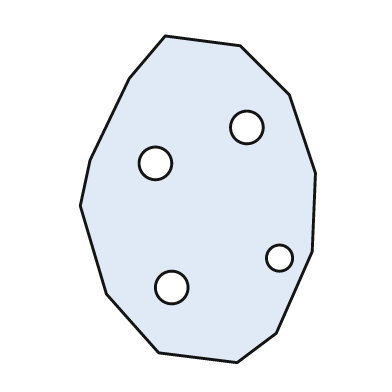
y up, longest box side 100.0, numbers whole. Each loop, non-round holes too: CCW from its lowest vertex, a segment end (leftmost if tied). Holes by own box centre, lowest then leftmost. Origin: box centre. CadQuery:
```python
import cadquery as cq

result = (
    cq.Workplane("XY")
    .moveTo(12.0, -50.0)
    .lineTo(24.0, -41.0)
    .lineTo(35.0, -16.0)
    .lineTo(36.0, 8.0)
    .lineTo(28.0, 32.0)
    .lineTo(13.0, 47.0)
    .lineTo(-10.0, 50.0)
    .lineTo(-21.0, 37.0)
    .lineTo(-33.0, 12.0)
    .lineTo(-36.0, -2.0)
    .lineTo(-28.0, -29.0)
    .lineTo(-12.0, -47.0)
    .close()
    .moveTo(-8.0, -27.0)
    .circle(5.0)
    .moveTo(25.0, -18.0)
    .circle(4.0)
    .moveTo(-13.0, 11.0)
    .circle(5.0)
    .moveTo(15.0, 22.0)
    .circle(5.0)
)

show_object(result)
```